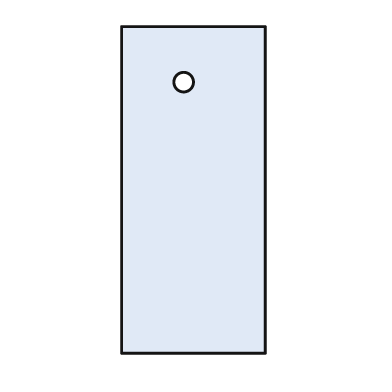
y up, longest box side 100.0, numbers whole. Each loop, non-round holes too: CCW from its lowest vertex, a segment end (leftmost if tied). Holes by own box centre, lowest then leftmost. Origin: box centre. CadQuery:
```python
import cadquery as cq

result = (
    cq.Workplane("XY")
    .moveTo(-22.0, -50.0)
    .lineTo(22.0, -50.0)
    .lineTo(22.0, 50.0)
    .lineTo(-22.0, 50.0)
    .close()
    .moveTo(-3.0, 33.0)
    .circle(3.0)
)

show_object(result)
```